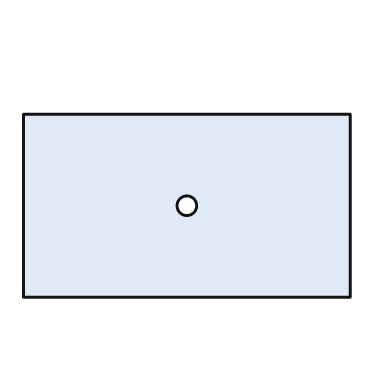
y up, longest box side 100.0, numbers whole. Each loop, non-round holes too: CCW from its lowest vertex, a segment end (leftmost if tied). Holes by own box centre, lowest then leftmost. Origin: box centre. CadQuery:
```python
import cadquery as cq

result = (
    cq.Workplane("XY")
    .moveTo(-50.0, -28.0)
    .lineTo(50.0, -28.0)
    .lineTo(50.0, 28.0)
    .lineTo(-50.0, 28.0)
    .close()
    .moveTo(0.0, 0.0)
    .circle(3.0)
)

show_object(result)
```